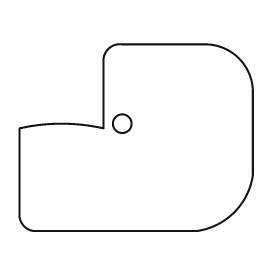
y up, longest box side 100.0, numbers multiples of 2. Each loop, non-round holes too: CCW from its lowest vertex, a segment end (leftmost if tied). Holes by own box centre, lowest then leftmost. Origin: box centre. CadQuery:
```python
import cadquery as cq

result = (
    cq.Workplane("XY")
    .moveTo(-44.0, -40.0)
    .lineTo(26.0, -40.0)
    .threePointArc((42.0, -32.0), (50.0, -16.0))
    .lineTo(50.0, 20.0)
    .threePointArc((44.0, 34.0), (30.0, 40.0))
    .lineTo(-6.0, 40.0)
    .threePointArc((-12.0, 38.0), (-14.0, 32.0))
    .lineTo(-14.0, 4.0)
    .threePointArc((-32.0, 6.0), (-50.0, 4.0))
    .lineTo(-50.0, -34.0)
    .threePointArc((-48.0, -38.0), (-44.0, -40.0))
    .close()
    .moveTo(-6.0, 6.0)
    .circle(4.0)
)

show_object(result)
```